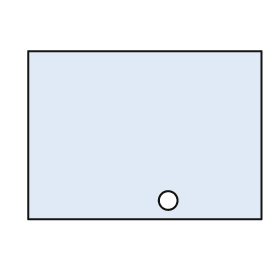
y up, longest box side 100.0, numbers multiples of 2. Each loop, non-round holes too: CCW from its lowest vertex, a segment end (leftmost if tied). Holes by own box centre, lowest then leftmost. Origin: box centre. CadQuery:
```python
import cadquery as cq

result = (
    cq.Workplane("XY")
    .moveTo(-50.0, -36.0)
    .lineTo(50.0, -36.0)
    .lineTo(50.0, 36.0)
    .lineTo(-50.0, 36.0)
    .close()
    .moveTo(10.0, -28.0)
    .circle(4.0)
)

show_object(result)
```